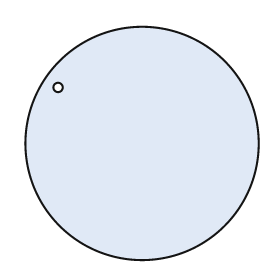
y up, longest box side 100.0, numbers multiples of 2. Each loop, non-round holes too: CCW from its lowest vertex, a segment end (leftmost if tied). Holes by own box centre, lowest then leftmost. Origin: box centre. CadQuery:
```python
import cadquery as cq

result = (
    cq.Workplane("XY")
    .moveTo(0.0, 0.0)
    .circle(50.0)
    .moveTo(-36.0, 24.0)
    .circle(2.0)
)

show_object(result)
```